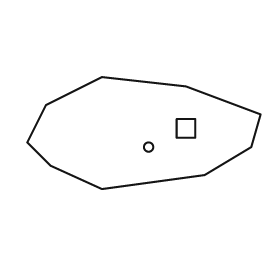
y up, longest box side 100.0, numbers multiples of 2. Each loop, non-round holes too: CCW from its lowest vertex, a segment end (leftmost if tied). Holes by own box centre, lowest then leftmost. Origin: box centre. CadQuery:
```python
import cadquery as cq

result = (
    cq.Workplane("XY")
    .moveTo(-18.0, -24.0)
    .lineTo(26.0, -18.0)
    .lineTo(46.0, -6.0)
    .lineTo(50.0, 8.0)
    .lineTo(18.0, 20.0)
    .lineTo(-18.0, 24.0)
    .lineTo(-42.0, 12.0)
    .lineTo(-50.0, -4.0)
    .lineTo(-40.0, -14.0)
    .close()
    .moveTo(2.0, -6.0)
    .circle(2.0)
    .moveTo(14.0, -2.0)
    .lineTo(22.0, -2.0)
    .lineTo(22.0, 6.0)
    .lineTo(14.0, 6.0)
    .close()
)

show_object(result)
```